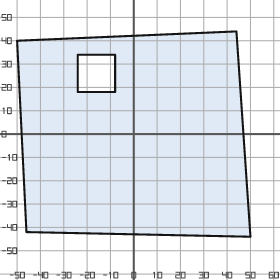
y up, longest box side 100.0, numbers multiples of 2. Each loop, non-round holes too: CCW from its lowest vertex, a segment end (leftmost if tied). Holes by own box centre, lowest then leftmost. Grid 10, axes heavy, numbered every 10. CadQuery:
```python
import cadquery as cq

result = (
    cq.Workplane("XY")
    .moveTo(50.0, -44.0)
    .lineTo(44.0, 44.0)
    .lineTo(-50.0, 40.0)
    .lineTo(-46.0, -42.0)
    .close()
    .moveTo(-24.0, 18.0)
    .lineTo(-8.0, 18.0)
    .lineTo(-8.0, 34.0)
    .lineTo(-24.0, 34.0)
    .close()
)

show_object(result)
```